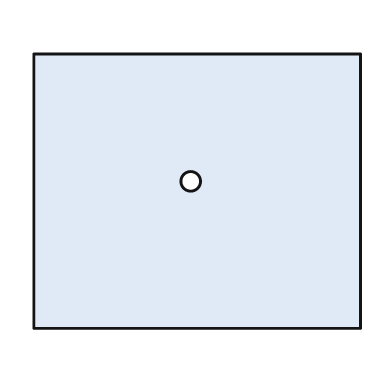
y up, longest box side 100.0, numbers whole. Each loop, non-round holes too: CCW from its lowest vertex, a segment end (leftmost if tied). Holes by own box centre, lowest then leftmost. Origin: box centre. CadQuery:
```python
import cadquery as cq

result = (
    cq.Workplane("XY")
    .moveTo(-50.0, -42.0)
    .lineTo(50.0, -42.0)
    .lineTo(50.0, 42.0)
    .lineTo(-50.0, 42.0)
    .close()
    .moveTo(-2.0, 3.0)
    .circle(3.0)
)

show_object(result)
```